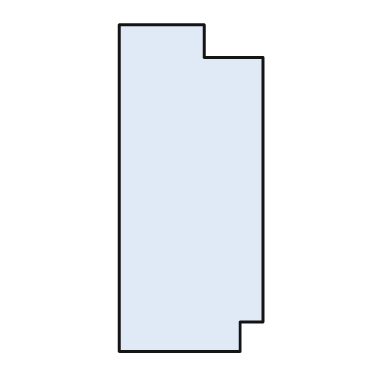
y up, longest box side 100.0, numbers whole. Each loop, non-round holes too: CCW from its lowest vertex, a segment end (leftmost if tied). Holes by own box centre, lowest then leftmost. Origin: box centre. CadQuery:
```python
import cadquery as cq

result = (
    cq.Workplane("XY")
    .moveTo(-22.0, -50.0)
    .lineTo(15.0, -50.0)
    .lineTo(15.0, -41.0)
    .lineTo(22.0, -41.0)
    .lineTo(22.0, 40.0)
    .lineTo(4.0, 40.0)
    .lineTo(4.0, 50.0)
    .lineTo(-22.0, 50.0)
    .close()
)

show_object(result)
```